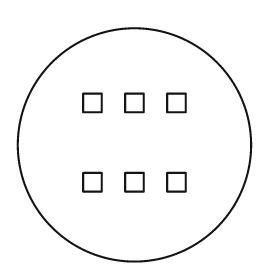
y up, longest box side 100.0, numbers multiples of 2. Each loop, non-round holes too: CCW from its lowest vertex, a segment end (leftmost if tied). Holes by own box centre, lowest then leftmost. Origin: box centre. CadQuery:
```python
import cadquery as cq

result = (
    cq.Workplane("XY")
    .moveTo(0.0, 0.0)
    .circle(50.0)
    .moveTo(-22.0, -20.0)
    .lineTo(-14.0, -20.0)
    .lineTo(-14.0, -12.0)
    .lineTo(-22.0, -12.0)
    .close()
    .moveTo(-4.0, -20.0)
    .lineTo(4.0, -20.0)
    .lineTo(4.0, -12.0)
    .lineTo(-4.0, -12.0)
    .close()
    .moveTo(14.0, -20.0)
    .lineTo(22.0, -20.0)
    .lineTo(22.0, -12.0)
    .lineTo(14.0, -12.0)
    .close()
    .moveTo(-22.0, 14.0)
    .lineTo(-14.0, 14.0)
    .lineTo(-14.0, 22.0)
    .lineTo(-22.0, 22.0)
    .close()
    .moveTo(-4.0, 14.0)
    .lineTo(4.0, 14.0)
    .lineTo(4.0, 22.0)
    .lineTo(-4.0, 22.0)
    .close()
    .moveTo(14.0, 14.0)
    .lineTo(22.0, 14.0)
    .lineTo(22.0, 22.0)
    .lineTo(14.0, 22.0)
    .close()
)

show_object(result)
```